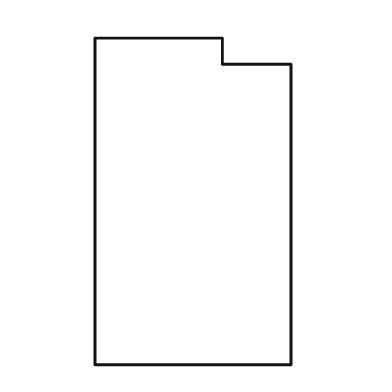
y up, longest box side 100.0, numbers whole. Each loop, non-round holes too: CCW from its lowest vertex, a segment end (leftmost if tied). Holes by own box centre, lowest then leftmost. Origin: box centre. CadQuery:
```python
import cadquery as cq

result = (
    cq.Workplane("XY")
    .moveTo(-30.0, -50.0)
    .lineTo(30.0, -50.0)
    .lineTo(30.0, 42.0)
    .lineTo(9.0, 42.0)
    .lineTo(9.0, 50.0)
    .lineTo(-30.0, 50.0)
    .close()
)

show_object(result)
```